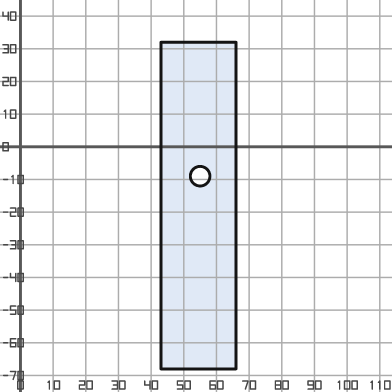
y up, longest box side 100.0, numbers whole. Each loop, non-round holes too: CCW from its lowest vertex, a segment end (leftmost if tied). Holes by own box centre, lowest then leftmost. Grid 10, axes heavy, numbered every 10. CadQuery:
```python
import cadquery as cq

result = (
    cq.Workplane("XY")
    .moveTo(43.0, -68.0)
    .lineTo(66.0, -68.0)
    .lineTo(66.0, 32.0)
    .lineTo(43.0, 32.0)
    .close()
    .moveTo(55.0, -9.0)
    .circle(3.0)
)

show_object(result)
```